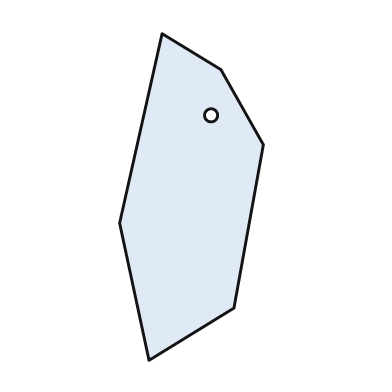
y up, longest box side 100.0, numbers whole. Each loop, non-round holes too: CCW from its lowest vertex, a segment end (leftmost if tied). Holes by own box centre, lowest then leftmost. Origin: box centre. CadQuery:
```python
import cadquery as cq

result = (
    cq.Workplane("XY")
    .moveTo(-13.0, -50.0)
    .lineTo(13.0, -34.0)
    .lineTo(22.0, 16.0)
    .lineTo(9.0, 39.0)
    .lineTo(-9.0, 50.0)
    .lineTo(-22.0, -8.0)
    .close()
    .moveTo(6.0, 25.0)
    .circle(2.0)
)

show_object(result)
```